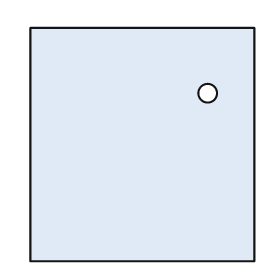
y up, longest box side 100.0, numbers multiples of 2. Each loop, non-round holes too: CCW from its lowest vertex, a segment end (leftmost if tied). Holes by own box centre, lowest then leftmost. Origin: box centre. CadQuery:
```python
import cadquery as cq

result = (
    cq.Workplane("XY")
    .moveTo(-48.0, -50.0)
    .lineTo(48.0, -50.0)
    .lineTo(48.0, 50.0)
    .lineTo(-48.0, 50.0)
    .close()
    .moveTo(28.0, 22.0)
    .circle(4.0)
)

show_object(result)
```